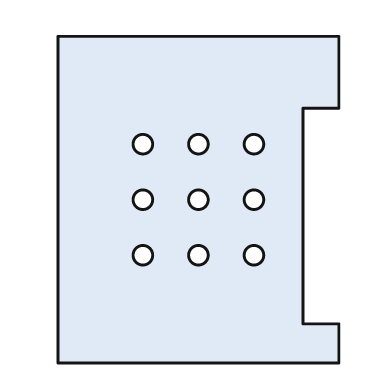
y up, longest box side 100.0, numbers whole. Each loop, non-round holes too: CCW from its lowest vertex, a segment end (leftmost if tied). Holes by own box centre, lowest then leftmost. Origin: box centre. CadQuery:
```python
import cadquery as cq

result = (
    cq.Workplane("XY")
    .moveTo(-43.0, -50.0)
    .lineTo(43.0, -50.0)
    .lineTo(43.0, -38.0)
    .lineTo(32.0, -38.0)
    .lineTo(32.0, 28.0)
    .lineTo(43.0, 28.0)
    .lineTo(43.0, 50.0)
    .lineTo(-43.0, 50.0)
    .close()
    .moveTo(-17.0, -17.0)
    .circle(3.0)
    .moveTo(0.0, -17.0)
    .circle(3.0)
    .moveTo(17.0, -17.0)
    .circle(3.0)
    .moveTo(-17.0, 0.0)
    .circle(3.0)
    .moveTo(0.0, 0.0)
    .circle(3.0)
    .moveTo(17.0, 0.0)
    .circle(3.0)
    .moveTo(-17.0, 17.0)
    .circle(3.0)
    .moveTo(0.0, 17.0)
    .circle(3.0)
    .moveTo(17.0, 17.0)
    .circle(3.0)
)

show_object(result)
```